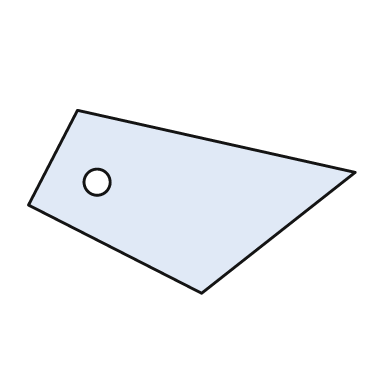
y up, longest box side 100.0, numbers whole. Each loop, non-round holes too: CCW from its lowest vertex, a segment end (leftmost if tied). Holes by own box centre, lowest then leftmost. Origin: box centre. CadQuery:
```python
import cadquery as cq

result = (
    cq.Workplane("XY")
    .moveTo(3.0, -28.0)
    .lineTo(50.0, 9.0)
    .lineTo(-35.0, 28.0)
    .lineTo(-50.0, -1.0)
    .close()
    .moveTo(-29.0, 6.0)
    .circle(4.0)
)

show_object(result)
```